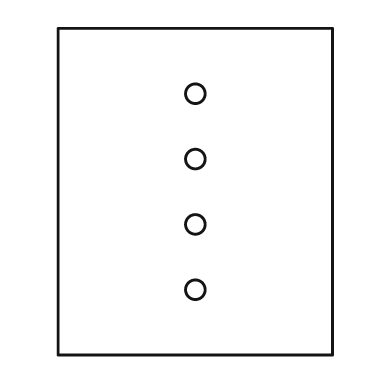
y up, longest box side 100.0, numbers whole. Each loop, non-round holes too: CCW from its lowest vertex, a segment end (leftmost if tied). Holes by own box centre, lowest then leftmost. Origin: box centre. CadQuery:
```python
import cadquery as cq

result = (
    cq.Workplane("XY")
    .moveTo(-42.0, -50.0)
    .lineTo(42.0, -50.0)
    .lineTo(42.0, 50.0)
    .lineTo(-42.0, 50.0)
    .close()
    .moveTo(0.0, -30.0)
    .circle(3.0)
    .moveTo(0.0, -10.0)
    .circle(3.0)
    .moveTo(0.0, 10.0)
    .circle(3.0)
    .moveTo(0.0, 30.0)
    .circle(3.0)
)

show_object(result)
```